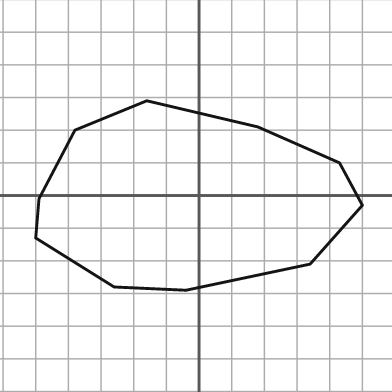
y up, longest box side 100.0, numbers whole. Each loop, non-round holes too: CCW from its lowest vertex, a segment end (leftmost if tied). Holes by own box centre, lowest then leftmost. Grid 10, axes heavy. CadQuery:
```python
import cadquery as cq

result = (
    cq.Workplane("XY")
    .moveTo(-4.0, -29.0)
    .lineTo(34.0, -21.0)
    .lineTo(50.0, -3.0)
    .lineTo(43.0, 10.0)
    .lineTo(18.0, 21.0)
    .lineTo(-16.0, 29.0)
    .lineTo(-38.0, 20.0)
    .lineTo(-49.0, -1.0)
    .lineTo(-50.0, -13.0)
    .lineTo(-26.0, -28.0)
    .close()
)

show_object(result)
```